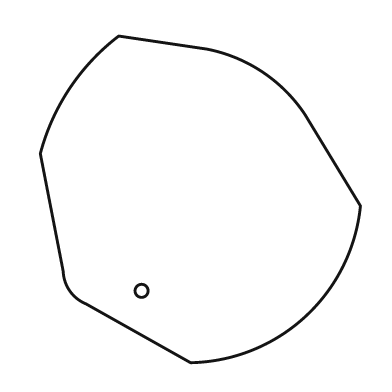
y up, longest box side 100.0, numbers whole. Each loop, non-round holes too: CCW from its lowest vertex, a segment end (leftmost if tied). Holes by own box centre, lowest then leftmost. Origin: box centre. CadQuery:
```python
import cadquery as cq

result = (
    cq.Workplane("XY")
    .moveTo(-3.0, -50.0)
    .threePointArc((32.0, -36.0), (49.0, -2.0))
    .lineTo(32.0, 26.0)
    .threePointArc((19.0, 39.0), (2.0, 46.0))
    .lineTo(-25.0, 50.0)
    .threePointArc((-40.0, 34.0), (-49.0, 14.0))
    .lineTo(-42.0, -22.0)
    .threePointArc((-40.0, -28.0), (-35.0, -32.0))
    .close()
    .moveTo(-18.0, -28.0)
    .circle(2.0)
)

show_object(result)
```